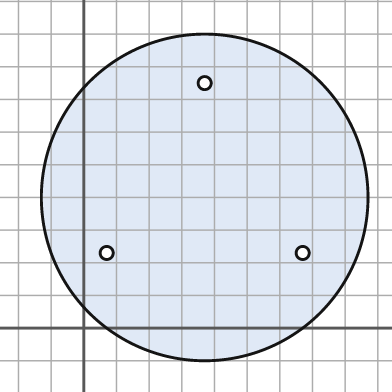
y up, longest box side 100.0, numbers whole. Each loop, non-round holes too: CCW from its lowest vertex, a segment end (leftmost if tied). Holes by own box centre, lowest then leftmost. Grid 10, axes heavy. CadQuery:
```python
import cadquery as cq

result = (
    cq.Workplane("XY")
    .moveTo(37.0, 40.0)
    .circle(50.0)
    .moveTo(7.0, 23.0)
    .circle(2.0)
    .moveTo(67.0, 23.0)
    .circle(2.0)
    .moveTo(37.0, 75.0)
    .circle(2.0)
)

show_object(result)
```